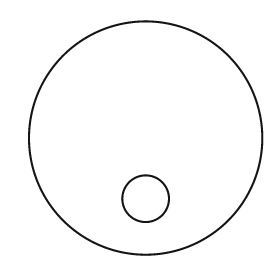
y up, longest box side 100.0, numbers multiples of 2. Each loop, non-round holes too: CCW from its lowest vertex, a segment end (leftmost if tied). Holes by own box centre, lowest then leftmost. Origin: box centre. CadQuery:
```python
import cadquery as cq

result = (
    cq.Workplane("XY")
    .moveTo(0.0, 0.0)
    .circle(50.0)
    .moveTo(0.0, -26.0)
    .circle(10.0)
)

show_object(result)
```